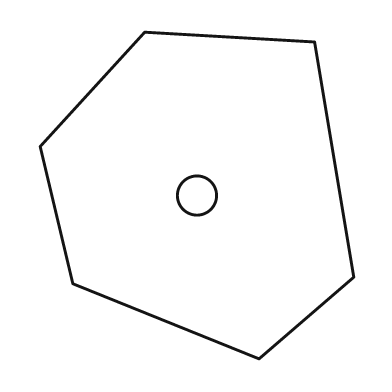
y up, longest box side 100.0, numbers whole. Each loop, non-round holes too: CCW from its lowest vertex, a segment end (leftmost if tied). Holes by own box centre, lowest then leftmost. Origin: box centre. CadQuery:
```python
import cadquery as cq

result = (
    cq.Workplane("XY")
    .moveTo(19.0, -50.0)
    .lineTo(48.0, -25.0)
    .lineTo(36.0, 47.0)
    .lineTo(-16.0, 50.0)
    .lineTo(-48.0, 15.0)
    .lineTo(-38.0, -27.0)
    .close()
    .moveTo(0.0, 0.0)
    .circle(6.0)
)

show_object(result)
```